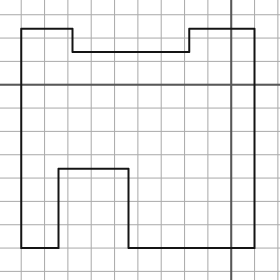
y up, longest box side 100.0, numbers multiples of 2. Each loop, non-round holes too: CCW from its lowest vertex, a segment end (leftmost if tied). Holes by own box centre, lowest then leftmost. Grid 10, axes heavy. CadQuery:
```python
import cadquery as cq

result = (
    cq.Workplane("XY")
    .moveTo(-90.0, -70.0)
    .lineTo(-74.0, -70.0)
    .lineTo(-74.0, -36.0)
    .lineTo(-44.0, -36.0)
    .lineTo(-44.0, -70.0)
    .lineTo(10.0, -70.0)
    .lineTo(10.0, 24.0)
    .lineTo(-18.0, 24.0)
    .lineTo(-18.0, 14.0)
    .lineTo(-68.0, 14.0)
    .lineTo(-68.0, 24.0)
    .lineTo(-90.0, 24.0)
    .close()
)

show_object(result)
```